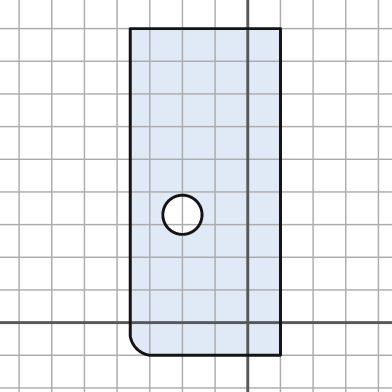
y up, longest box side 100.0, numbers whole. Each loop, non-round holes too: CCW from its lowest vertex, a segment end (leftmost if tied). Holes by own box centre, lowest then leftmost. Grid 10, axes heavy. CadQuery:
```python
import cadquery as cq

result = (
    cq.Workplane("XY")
    .moveTo(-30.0, -10.0)
    .lineTo(10.0, -10.0)
    .lineTo(10.0, 90.0)
    .lineTo(-36.0, 90.0)
    .lineTo(-36.0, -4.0)
    .threePointArc((-34.0, -8.0), (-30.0, -10.0))
    .close()
    .moveTo(-20.0, 33.0)
    .circle(6.0)
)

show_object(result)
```